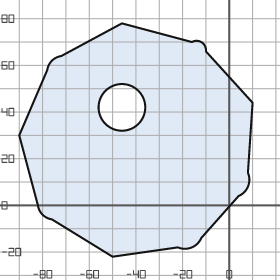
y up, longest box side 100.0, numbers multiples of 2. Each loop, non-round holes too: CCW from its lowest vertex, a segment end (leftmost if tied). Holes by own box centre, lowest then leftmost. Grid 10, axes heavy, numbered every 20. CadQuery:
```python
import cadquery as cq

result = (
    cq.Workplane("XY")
    .moveTo(-50.0, -22.0)
    .lineTo(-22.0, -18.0)
    .threePointArc((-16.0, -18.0), (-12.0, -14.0))
    .lineTo(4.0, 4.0)
    .threePointArc((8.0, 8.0), (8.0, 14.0))
    .lineTo(10.0, 44.0)
    .lineTo(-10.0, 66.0)
    .threePointArc((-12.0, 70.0), (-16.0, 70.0))
    .lineTo(-46.0, 78.0)
    .lineTo(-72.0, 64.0)
    .threePointArc((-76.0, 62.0), (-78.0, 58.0))
    .lineTo(-90.0, 30.0)
    .lineTo(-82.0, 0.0)
    .threePointArc((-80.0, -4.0), (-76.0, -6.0))
    .close()
    .moveTo(-46.0, 42.0)
    .circle(10.0)
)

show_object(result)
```